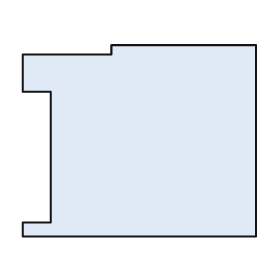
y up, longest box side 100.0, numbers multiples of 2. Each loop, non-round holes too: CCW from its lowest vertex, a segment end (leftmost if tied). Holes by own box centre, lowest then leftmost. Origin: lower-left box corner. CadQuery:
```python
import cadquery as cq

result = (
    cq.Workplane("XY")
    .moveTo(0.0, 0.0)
    .lineTo(100.0, 0.0)
    .lineTo(100.0, 82.0)
    .lineTo(38.0, 82.0)
    .lineTo(38.0, 78.0)
    .lineTo(0.0, 78.0)
    .lineTo(0.0, 62.0)
    .lineTo(12.0, 62.0)
    .lineTo(12.0, 6.0)
    .lineTo(0.0, 6.0)
    .close()
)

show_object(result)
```